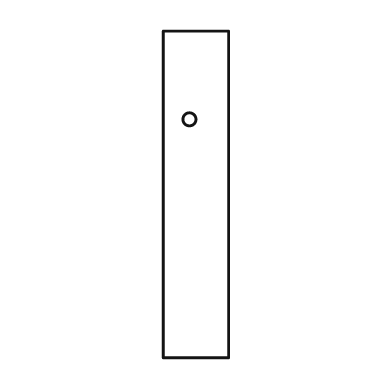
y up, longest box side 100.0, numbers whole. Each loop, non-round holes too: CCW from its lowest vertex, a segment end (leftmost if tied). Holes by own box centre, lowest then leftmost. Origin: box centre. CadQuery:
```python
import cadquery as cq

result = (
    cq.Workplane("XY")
    .moveTo(-10.0, -50.0)
    .lineTo(10.0, -50.0)
    .lineTo(10.0, 50.0)
    .lineTo(-10.0, 50.0)
    .close()
    .moveTo(-2.0, 23.0)
    .circle(2.0)
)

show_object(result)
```